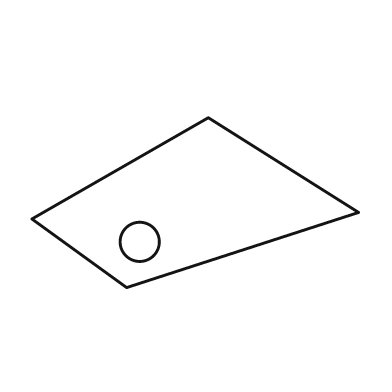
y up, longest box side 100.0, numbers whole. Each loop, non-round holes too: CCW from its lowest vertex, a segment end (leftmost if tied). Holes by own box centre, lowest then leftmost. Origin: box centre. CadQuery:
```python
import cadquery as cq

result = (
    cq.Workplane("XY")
    .moveTo(-21.0, -26.0)
    .lineTo(50.0, -3.0)
    .lineTo(4.0, 26.0)
    .lineTo(-50.0, -5.0)
    .close()
    .moveTo(-17.0, -12.0)
    .circle(6.0)
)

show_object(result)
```